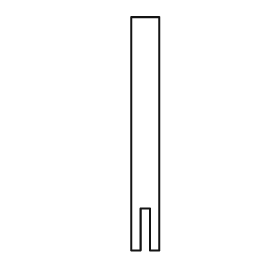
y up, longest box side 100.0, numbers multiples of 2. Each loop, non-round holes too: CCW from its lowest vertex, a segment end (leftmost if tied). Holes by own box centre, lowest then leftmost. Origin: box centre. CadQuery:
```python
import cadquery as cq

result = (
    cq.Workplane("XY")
    .moveTo(-6.0, -50.0)
    .lineTo(-2.0, -50.0)
    .lineTo(-2.0, -32.0)
    .lineTo(2.0, -32.0)
    .lineTo(2.0, -50.0)
    .lineTo(6.0, -50.0)
    .lineTo(6.0, 50.0)
    .lineTo(-6.0, 50.0)
    .close()
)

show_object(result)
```